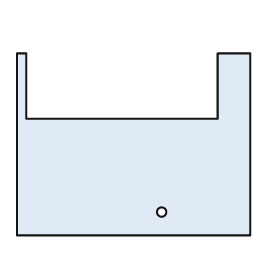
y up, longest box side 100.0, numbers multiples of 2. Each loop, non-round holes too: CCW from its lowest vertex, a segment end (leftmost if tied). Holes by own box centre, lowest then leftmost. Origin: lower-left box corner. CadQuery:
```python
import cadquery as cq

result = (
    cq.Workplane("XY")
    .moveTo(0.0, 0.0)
    .lineTo(100.0, 0.0)
    .lineTo(100.0, 78.0)
    .lineTo(86.0, 78.0)
    .lineTo(86.0, 50.0)
    .lineTo(4.0, 50.0)
    .lineTo(4.0, 78.0)
    .lineTo(0.0, 78.0)
    .close()
    .moveTo(62.0, 10.0)
    .circle(2.0)
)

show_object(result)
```